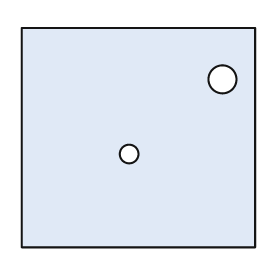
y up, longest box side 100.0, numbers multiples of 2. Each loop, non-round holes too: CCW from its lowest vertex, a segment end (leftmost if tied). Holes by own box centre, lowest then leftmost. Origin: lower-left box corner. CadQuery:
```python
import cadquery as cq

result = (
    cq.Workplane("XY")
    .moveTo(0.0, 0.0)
    .lineTo(100.0, 0.0)
    .lineTo(100.0, 94.0)
    .lineTo(0.0, 94.0)
    .close()
    .moveTo(46.0, 40.0)
    .circle(4.0)
    .moveTo(86.0, 72.0)
    .circle(6.0)
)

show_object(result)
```